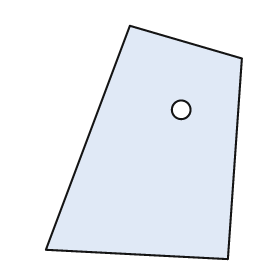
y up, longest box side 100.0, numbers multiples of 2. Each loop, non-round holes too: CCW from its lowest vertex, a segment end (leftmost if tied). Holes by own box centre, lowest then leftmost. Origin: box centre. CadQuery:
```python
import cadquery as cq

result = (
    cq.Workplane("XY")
    .moveTo(36.0, -50.0)
    .lineTo(42.0, 36.0)
    .lineTo(-6.0, 50.0)
    .lineTo(-42.0, -46.0)
    .close()
    .moveTo(16.0, 14.0)
    .circle(4.0)
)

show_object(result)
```